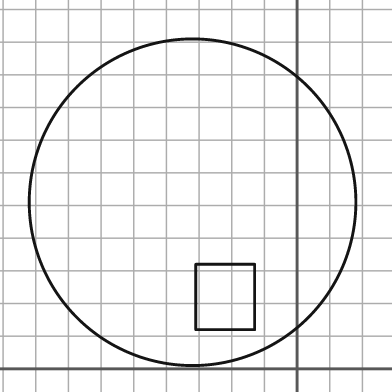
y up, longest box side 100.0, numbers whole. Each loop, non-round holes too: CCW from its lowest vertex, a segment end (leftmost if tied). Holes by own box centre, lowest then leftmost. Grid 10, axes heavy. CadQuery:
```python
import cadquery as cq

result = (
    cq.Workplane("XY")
    .moveTo(-32.0, 51.0)
    .circle(50.0)
    .moveTo(-31.0, 12.0)
    .lineTo(-13.0, 12.0)
    .lineTo(-13.0, 32.0)
    .lineTo(-31.0, 32.0)
    .close()
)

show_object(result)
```